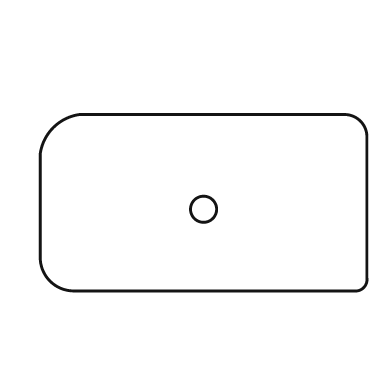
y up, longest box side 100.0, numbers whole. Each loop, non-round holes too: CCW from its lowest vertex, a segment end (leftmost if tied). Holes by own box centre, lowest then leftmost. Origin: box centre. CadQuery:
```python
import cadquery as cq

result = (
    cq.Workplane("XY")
    .moveTo(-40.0, -27.0)
    .lineTo(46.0, -27.0)
    .threePointArc((49.0, -26.0), (50.0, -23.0))
    .lineTo(50.0, 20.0)
    .threePointArc((48.0, 25.0), (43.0, 27.0))
    .lineTo(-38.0, 27.0)
    .threePointArc((-46.0, 23.0), (-50.0, 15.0))
    .lineTo(-50.0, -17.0)
    .threePointArc((-47.0, -24.0), (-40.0, -27.0))
    .close()
    .moveTo(0.0, -2.0)
    .circle(4.0)
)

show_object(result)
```